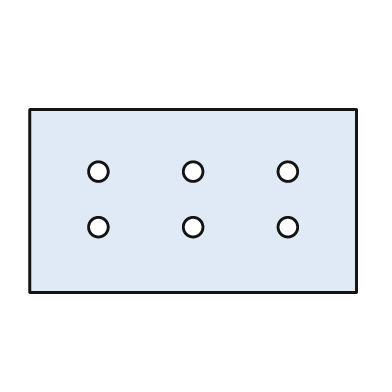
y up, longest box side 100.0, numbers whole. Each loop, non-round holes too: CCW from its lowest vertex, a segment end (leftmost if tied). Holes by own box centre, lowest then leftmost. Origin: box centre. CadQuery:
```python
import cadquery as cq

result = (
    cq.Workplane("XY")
    .moveTo(-50.0, -28.0)
    .lineTo(50.0, -28.0)
    .lineTo(50.0, 28.0)
    .lineTo(-50.0, 28.0)
    .close()
    .moveTo(-29.0, -8.0)
    .circle(3.0)
    .moveTo(0.0, -8.0)
    .circle(3.0)
    .moveTo(29.0, -8.0)
    .circle(3.0)
    .moveTo(-29.0, 9.0)
    .circle(3.0)
    .moveTo(0.0, 9.0)
    .circle(3.0)
    .moveTo(29.0, 9.0)
    .circle(3.0)
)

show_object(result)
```